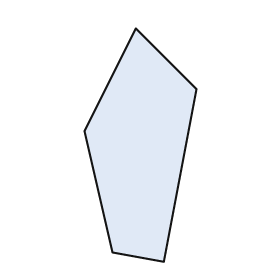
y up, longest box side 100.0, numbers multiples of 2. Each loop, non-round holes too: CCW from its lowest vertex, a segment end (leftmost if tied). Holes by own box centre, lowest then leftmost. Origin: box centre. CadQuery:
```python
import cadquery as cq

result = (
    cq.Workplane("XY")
    .moveTo(10.0, -50.0)
    .lineTo(24.0, 24.0)
    .lineTo(-2.0, 50.0)
    .lineTo(-24.0, 6.0)
    .lineTo(-12.0, -46.0)
    .close()
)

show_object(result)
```